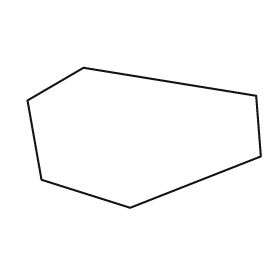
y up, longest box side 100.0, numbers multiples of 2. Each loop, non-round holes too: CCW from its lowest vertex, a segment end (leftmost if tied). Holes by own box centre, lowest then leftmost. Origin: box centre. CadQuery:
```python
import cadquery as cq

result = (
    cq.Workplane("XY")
    .moveTo(-6.0, -30.0)
    .lineTo(50.0, -8.0)
    .lineTo(48.0, 18.0)
    .lineTo(-26.0, 30.0)
    .lineTo(-50.0, 16.0)
    .lineTo(-44.0, -18.0)
    .close()
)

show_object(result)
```